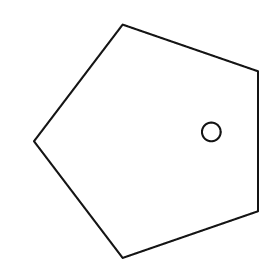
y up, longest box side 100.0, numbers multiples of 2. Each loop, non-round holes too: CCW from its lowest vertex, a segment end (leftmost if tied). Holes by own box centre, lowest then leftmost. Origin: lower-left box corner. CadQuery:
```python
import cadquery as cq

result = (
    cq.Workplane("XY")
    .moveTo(38.0, 0.0)
    .lineTo(96.0, 20.0)
    .lineTo(96.0, 80.0)
    .lineTo(38.0, 100.0)
    .lineTo(0.0, 50.0)
    .close()
    .moveTo(76.0, 54.0)
    .circle(4.0)
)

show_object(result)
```